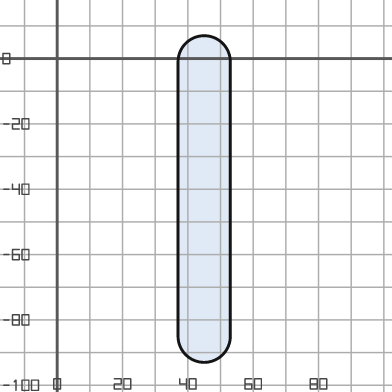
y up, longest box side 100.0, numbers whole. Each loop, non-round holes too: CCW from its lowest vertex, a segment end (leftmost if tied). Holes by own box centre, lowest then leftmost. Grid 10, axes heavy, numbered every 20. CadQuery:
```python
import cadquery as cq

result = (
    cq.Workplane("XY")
    .moveTo(37.0, -85.0)
    .threePointArc((45.0, -93.0), (53.0, -85.0))
    .lineTo(53.0, -1.0)
    .threePointArc((45.0, 7.0), (37.0, -1.0))
    .close()
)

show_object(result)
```